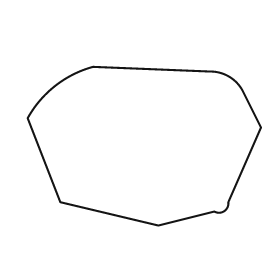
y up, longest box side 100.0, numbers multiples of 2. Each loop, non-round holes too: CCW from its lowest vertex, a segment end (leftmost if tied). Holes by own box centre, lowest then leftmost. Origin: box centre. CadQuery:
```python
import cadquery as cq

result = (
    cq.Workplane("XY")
    .moveTo(6.0, -34.0)
    .lineTo(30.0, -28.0)
    .threePointArc((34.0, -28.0), (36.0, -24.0))
    .lineTo(50.0, 8.0)
    .lineTo(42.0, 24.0)
    .threePointArc((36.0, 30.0), (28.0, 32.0))
    .lineTo(-22.0, 34.0)
    .threePointArc((-38.0, 26.0), (-50.0, 12.0))
    .lineTo(-36.0, -24.0)
    .close()
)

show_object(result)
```